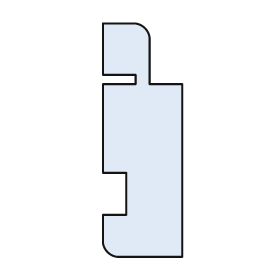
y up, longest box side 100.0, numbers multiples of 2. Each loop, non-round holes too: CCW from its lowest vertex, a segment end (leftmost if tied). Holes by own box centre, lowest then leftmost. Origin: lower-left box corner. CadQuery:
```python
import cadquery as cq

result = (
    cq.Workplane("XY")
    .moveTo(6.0, 0.0)
    .lineTo(34.0, 0.0)
    .lineTo(34.0, 74.0)
    .lineTo(20.0, 74.0)
    .lineTo(20.0, 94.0)
    .threePointArc((18.0, 98.0), (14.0, 100.0))
    .lineTo(0.0, 100.0)
    .lineTo(0.0, 78.0)
    .lineTo(14.0, 78.0)
    .lineTo(14.0, 74.0)
    .lineTo(0.0, 74.0)
    .lineTo(0.0, 36.0)
    .lineTo(10.0, 36.0)
    .lineTo(10.0, 18.0)
    .lineTo(0.0, 18.0)
    .lineTo(0.0, 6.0)
    .threePointArc((2.0, 2.0), (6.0, 0.0))
    .close()
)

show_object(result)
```